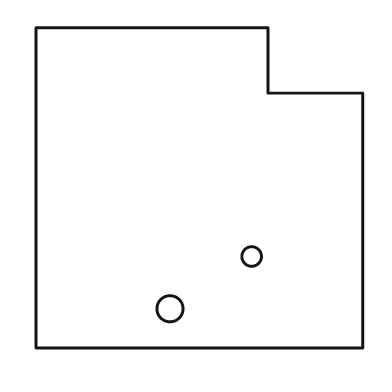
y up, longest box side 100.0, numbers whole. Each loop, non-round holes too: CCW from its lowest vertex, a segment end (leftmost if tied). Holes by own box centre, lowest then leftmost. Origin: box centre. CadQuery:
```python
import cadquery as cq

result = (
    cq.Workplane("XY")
    .moveTo(-50.0, -49.0)
    .lineTo(50.0, -49.0)
    .lineTo(50.0, 29.0)
    .lineTo(21.0, 29.0)
    .lineTo(21.0, 49.0)
    .lineTo(-50.0, 49.0)
    .close()
    .moveTo(-9.0, -37.0)
    .circle(4.0)
    .moveTo(16.0, -21.0)
    .circle(3.0)
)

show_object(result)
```